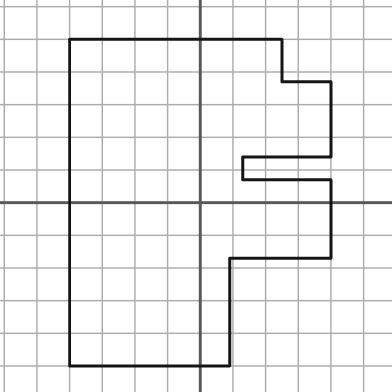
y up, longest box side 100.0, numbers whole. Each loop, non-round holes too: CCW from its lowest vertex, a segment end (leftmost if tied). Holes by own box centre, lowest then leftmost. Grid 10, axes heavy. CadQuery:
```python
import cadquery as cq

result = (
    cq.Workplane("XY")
    .moveTo(-40.0, -50.0)
    .lineTo(9.0, -50.0)
    .lineTo(9.0, -17.0)
    .lineTo(40.0, -17.0)
    .lineTo(40.0, 7.0)
    .lineTo(13.0, 7.0)
    .lineTo(13.0, 14.0)
    .lineTo(40.0, 14.0)
    .lineTo(40.0, 37.0)
    .lineTo(25.0, 37.0)
    .lineTo(25.0, 50.0)
    .lineTo(-40.0, 50.0)
    .close()
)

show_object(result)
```